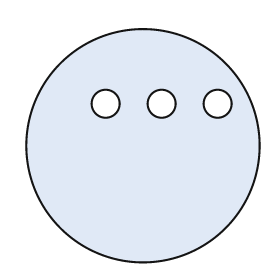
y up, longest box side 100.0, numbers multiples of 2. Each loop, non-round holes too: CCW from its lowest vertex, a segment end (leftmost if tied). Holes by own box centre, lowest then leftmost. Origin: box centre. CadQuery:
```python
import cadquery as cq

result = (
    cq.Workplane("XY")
    .moveTo(0.0, 0.0)
    .circle(50.0)
    .moveTo(-16.0, 18.0)
    .circle(6.0)
    .moveTo(8.0, 18.0)
    .circle(6.0)
    .moveTo(32.0, 18.0)
    .circle(6.0)
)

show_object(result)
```